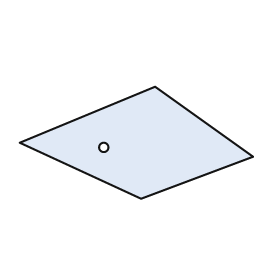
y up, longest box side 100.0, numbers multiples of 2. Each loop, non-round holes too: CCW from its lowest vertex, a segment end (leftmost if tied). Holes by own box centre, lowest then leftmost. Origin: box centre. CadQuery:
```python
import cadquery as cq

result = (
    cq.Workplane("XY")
    .moveTo(2.0, -24.0)
    .lineTo(50.0, -6.0)
    .lineTo(8.0, 24.0)
    .lineTo(-50.0, 0.0)
    .close()
    .moveTo(-14.0, -2.0)
    .circle(2.0)
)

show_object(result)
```